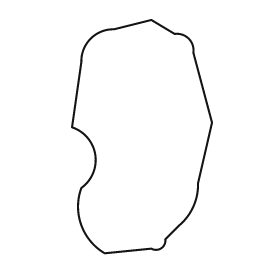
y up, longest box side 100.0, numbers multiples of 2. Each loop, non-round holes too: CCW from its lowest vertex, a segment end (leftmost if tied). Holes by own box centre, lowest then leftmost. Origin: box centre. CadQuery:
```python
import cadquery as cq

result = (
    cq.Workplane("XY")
    .moveTo(-16.0, -50.0)
    .lineTo(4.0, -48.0)
    .threePointArc((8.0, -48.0), (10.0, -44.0))
    .lineTo(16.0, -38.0)
    .threePointArc((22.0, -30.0), (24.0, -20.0))
    .lineTo(30.0, 6.0)
    .lineTo(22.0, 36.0)
    .threePointArc((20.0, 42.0), (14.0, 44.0))
    .lineTo(4.0, 50.0)
    .lineTo(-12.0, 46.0)
    .threePointArc((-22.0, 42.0), (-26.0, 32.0))
    .lineTo(-30.0, 4.0)
    .threePointArc((-20.0, -8.0), (-26.0, -22.0))
    .threePointArc((-26.0, -38.0), (-16.0, -50.0))
    .close()
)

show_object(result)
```